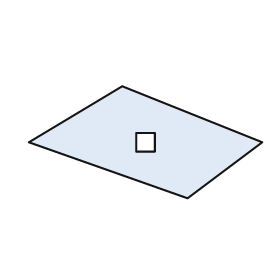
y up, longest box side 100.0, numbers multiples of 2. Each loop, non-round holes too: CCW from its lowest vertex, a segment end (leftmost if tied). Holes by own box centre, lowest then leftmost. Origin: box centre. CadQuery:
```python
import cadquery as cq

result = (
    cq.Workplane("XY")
    .moveTo(18.0, -24.0)
    .lineTo(50.0, 0.0)
    .lineTo(-10.0, 24.0)
    .lineTo(-50.0, 0.0)
    .close()
    .moveTo(-4.0, -4.0)
    .lineTo(4.0, -4.0)
    .lineTo(4.0, 4.0)
    .lineTo(-4.0, 4.0)
    .close()
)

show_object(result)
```